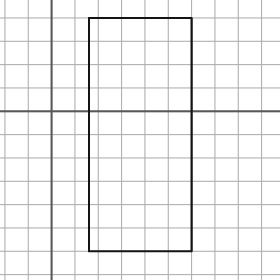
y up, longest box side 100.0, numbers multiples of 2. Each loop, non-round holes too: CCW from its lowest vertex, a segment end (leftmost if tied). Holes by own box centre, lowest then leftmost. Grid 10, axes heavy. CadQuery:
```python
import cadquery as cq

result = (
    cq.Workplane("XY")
    .moveTo(16.0, -60.0)
    .lineTo(60.0, -60.0)
    .lineTo(60.0, 40.0)
    .lineTo(16.0, 40.0)
    .close()
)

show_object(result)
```